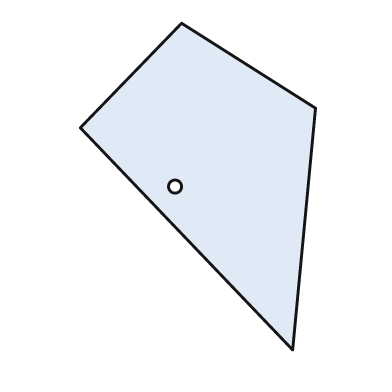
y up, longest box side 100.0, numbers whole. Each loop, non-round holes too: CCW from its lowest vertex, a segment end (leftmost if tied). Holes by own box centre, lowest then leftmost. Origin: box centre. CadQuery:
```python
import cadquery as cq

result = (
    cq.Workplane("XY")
    .moveTo(29.0, -50.0)
    .lineTo(36.0, 24.0)
    .lineTo(-5.0, 50.0)
    .lineTo(-36.0, 18.0)
    .close()
    .moveTo(-7.0, 0.0)
    .circle(2.0)
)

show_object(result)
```